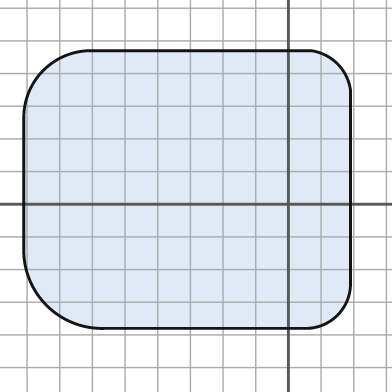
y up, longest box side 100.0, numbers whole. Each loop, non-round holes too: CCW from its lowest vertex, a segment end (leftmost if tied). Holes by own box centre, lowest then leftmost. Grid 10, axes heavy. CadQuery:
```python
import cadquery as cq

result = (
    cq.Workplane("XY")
    .moveTo(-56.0, -38.0)
    .lineTo(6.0, -38.0)
    .threePointArc((15.0, -34.0), (19.0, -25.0))
    .lineTo(19.0, 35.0)
    .threePointArc((15.0, 43.0), (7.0, 47.0))
    .lineTo(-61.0, 47.0)
    .threePointArc((-75.0, 41.0), (-81.0, 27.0))
    .lineTo(-81.0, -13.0)
    .threePointArc((-74.0, -31.0), (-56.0, -38.0))
    .close()
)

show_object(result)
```